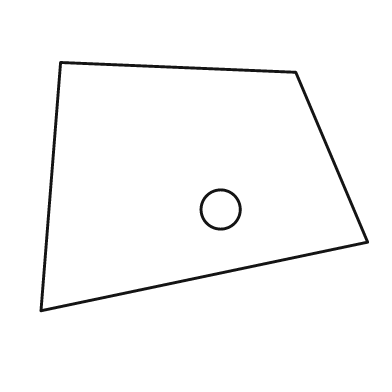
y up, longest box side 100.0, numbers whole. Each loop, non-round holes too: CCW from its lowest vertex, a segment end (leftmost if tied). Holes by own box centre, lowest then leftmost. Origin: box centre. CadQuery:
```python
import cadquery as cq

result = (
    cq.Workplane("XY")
    .moveTo(-50.0, -38.0)
    .lineTo(50.0, -17.0)
    .lineTo(28.0, 35.0)
    .lineTo(-44.0, 38.0)
    .close()
    .moveTo(5.0, -7.0)
    .circle(6.0)
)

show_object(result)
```